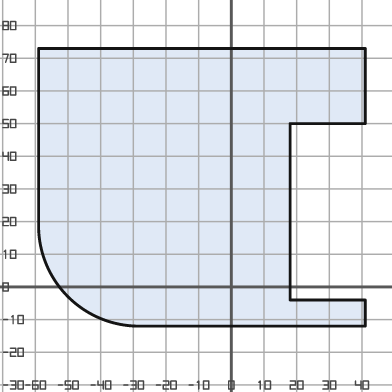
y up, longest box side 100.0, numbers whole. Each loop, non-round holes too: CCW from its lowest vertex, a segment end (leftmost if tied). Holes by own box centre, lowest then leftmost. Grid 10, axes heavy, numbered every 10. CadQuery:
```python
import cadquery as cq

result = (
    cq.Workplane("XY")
    .moveTo(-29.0, -12.0)
    .lineTo(41.0, -12.0)
    .lineTo(41.0, -4.0)
    .lineTo(18.0, -4.0)
    .lineTo(18.0, 50.0)
    .lineTo(41.0, 50.0)
    .lineTo(41.0, 73.0)
    .lineTo(-59.0, 73.0)
    .lineTo(-59.0, 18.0)
    .threePointArc((-50.0, -3.0), (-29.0, -12.0))
    .close()
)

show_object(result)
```